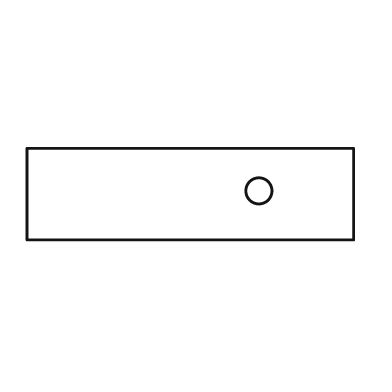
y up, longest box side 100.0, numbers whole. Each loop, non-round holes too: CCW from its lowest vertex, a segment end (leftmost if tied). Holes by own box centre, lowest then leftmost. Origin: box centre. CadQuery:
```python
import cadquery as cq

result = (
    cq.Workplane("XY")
    .moveTo(-50.0, -14.0)
    .lineTo(50.0, -14.0)
    .lineTo(50.0, 14.0)
    .lineTo(-50.0, 14.0)
    .close()
    .moveTo(21.0, 1.0)
    .circle(4.0)
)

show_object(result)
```